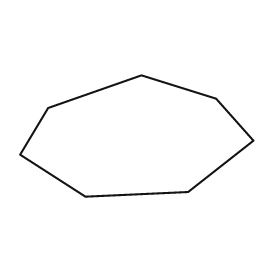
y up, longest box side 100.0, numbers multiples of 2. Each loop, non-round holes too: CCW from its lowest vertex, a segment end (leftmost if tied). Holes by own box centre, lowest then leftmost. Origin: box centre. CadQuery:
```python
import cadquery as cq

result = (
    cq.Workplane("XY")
    .moveTo(-22.0, -26.0)
    .lineTo(22.0, -24.0)
    .lineTo(50.0, -2.0)
    .lineTo(34.0, 16.0)
    .lineTo(2.0, 26.0)
    .lineTo(-38.0, 12.0)
    .lineTo(-50.0, -8.0)
    .close()
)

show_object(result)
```